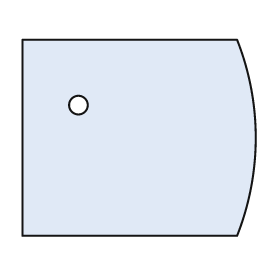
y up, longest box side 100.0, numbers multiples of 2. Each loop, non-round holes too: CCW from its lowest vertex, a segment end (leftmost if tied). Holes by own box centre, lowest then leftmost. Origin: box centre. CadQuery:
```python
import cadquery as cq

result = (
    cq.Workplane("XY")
    .moveTo(-50.0, -42.0)
    .lineTo(42.0, -42.0)
    .threePointArc((50.0, 0.0), (42.0, 42.0))
    .lineTo(-50.0, 42.0)
    .close()
    .moveTo(-26.0, 14.0)
    .circle(4.0)
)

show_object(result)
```